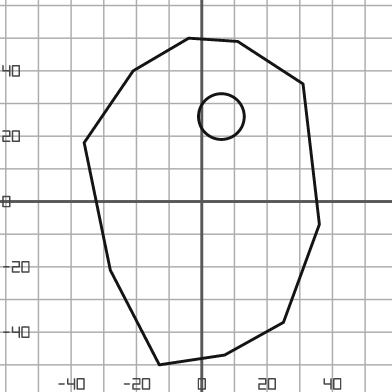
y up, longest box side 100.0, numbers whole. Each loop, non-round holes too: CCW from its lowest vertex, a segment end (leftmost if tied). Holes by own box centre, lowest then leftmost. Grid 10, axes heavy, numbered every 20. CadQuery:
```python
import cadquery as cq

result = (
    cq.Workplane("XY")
    .moveTo(-13.0, -50.0)
    .lineTo(7.0, -47.0)
    .lineTo(25.0, -37.0)
    .lineTo(36.0, -7.0)
    .lineTo(31.0, 36.0)
    .lineTo(11.0, 49.0)
    .lineTo(-4.0, 50.0)
    .lineTo(-21.0, 40.0)
    .lineTo(-36.0, 18.0)
    .lineTo(-28.0, -21.0)
    .close()
    .moveTo(6.0, 26.0)
    .circle(7.0)
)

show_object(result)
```